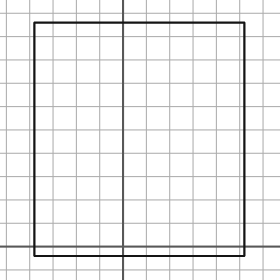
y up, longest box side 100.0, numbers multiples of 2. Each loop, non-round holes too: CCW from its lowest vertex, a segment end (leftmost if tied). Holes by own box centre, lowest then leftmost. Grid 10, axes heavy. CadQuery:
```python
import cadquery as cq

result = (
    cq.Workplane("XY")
    .moveTo(-38.0, -4.0)
    .lineTo(52.0, -4.0)
    .lineTo(52.0, 96.0)
    .lineTo(-38.0, 96.0)
    .close()
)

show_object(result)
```